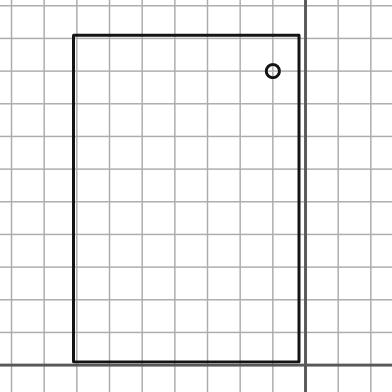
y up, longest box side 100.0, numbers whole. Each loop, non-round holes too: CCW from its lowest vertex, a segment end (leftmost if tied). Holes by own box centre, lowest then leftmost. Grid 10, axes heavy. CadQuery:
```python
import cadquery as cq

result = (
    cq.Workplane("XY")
    .moveTo(-71.0, 1.0)
    .lineTo(-2.0, 1.0)
    .lineTo(-2.0, 101.0)
    .lineTo(-71.0, 101.0)
    .close()
    .moveTo(-10.0, 90.0)
    .circle(2.0)
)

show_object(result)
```